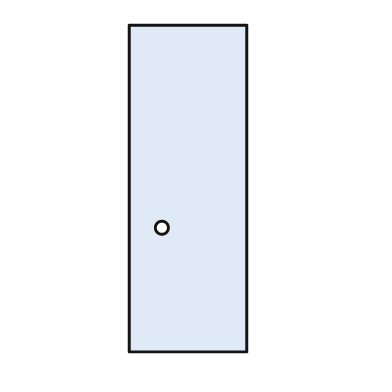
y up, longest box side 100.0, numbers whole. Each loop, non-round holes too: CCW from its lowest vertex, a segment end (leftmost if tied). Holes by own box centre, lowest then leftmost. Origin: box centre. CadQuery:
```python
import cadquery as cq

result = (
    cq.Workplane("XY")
    .moveTo(-18.0, -50.0)
    .lineTo(18.0, -50.0)
    .lineTo(18.0, 50.0)
    .lineTo(-18.0, 50.0)
    .close()
    .moveTo(-8.0, -12.0)
    .circle(2.0)
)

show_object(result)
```